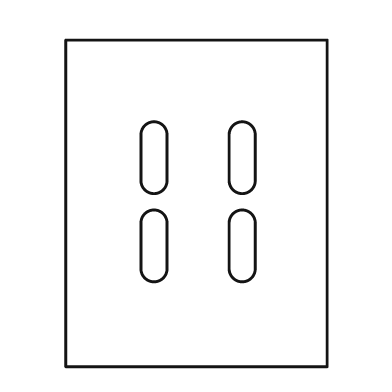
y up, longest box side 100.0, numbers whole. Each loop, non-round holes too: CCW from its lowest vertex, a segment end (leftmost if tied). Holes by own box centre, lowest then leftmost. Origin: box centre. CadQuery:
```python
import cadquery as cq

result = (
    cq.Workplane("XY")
    .moveTo(-40.0, -50.0)
    .lineTo(40.0, -50.0)
    .lineTo(40.0, 50.0)
    .lineTo(-40.0, 50.0)
    .close()
    .moveTo(-17.0, -20.0)
    .threePointArc((-13.0, -24.0), (-9.0, -20.0))
    .lineTo(-9.0, -6.0)
    .threePointArc((-13.0, -2.0), (-17.0, -6.0))
    .close()
    .moveTo(10.0, -20.0)
    .threePointArc((14.0, -24.0), (18.0, -20.0))
    .lineTo(18.0, -6.0)
    .threePointArc((14.0, -2.0), (10.0, -6.0))
    .close()
    .moveTo(-17.0, 7.0)
    .threePointArc((-13.0, 3.0), (-9.0, 7.0))
    .lineTo(-9.0, 21.0)
    .threePointArc((-13.0, 25.0), (-17.0, 21.0))
    .close()
    .moveTo(10.0, 7.0)
    .threePointArc((14.0, 3.0), (18.0, 7.0))
    .lineTo(18.0, 21.0)
    .threePointArc((14.0, 25.0), (10.0, 21.0))
    .close()
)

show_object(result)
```